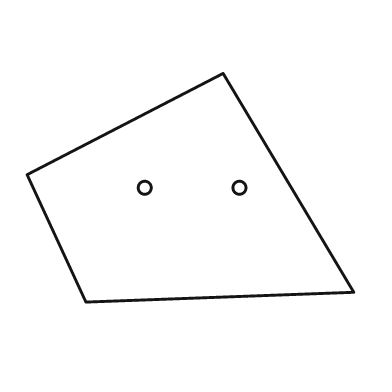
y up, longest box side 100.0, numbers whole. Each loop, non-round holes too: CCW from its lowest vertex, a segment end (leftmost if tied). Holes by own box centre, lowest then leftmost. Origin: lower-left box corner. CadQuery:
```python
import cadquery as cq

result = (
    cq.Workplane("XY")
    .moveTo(18.0, 0.0)
    .lineTo(100.0, 3.0)
    .lineTo(60.0, 70.0)
    .lineTo(0.0, 39.0)
    .close()
    .moveTo(36.0, 35.0)
    .circle(2.0)
    .moveTo(65.0, 35.0)
    .circle(2.0)
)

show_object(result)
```